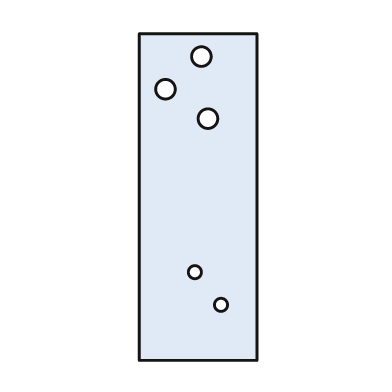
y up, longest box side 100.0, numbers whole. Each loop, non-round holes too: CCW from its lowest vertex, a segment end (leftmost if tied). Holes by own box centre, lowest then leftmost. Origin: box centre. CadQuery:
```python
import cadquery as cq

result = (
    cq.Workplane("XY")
    .moveTo(-18.0, -50.0)
    .lineTo(18.0, -50.0)
    .lineTo(18.0, 50.0)
    .lineTo(-18.0, 50.0)
    .close()
    .moveTo(7.0, -33.0)
    .circle(2.0)
    .moveTo(-1.0, -23.0)
    .circle(2.0)
    .moveTo(3.0, 24.0)
    .circle(3.0)
    .moveTo(-10.0, 33.0)
    .circle(3.0)
    .moveTo(1.0, 43.0)
    .circle(3.0)
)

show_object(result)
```